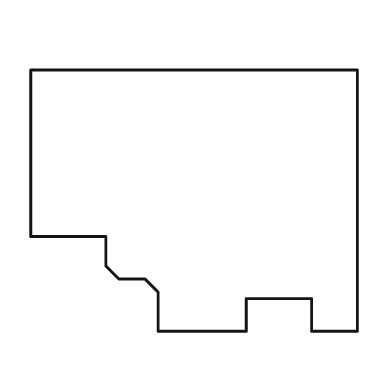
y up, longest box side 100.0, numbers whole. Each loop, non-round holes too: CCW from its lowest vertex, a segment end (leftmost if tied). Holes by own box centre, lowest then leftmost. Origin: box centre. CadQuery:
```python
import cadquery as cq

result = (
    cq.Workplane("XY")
    .moveTo(-11.0, -40.0)
    .lineTo(16.0, -40.0)
    .lineTo(16.0, -30.0)
    .lineTo(36.0, -30.0)
    .lineTo(36.0, -40.0)
    .lineTo(50.0, -40.0)
    .lineTo(50.0, 40.0)
    .lineTo(-50.0, 40.0)
    .lineTo(-50.0, -11.0)
    .lineTo(-27.0, -11.0)
    .lineTo(-27.0, -20.0)
    .lineTo(-23.0, -24.0)
    .lineTo(-15.0, -24.0)
    .lineTo(-11.0, -28.0)
    .close()
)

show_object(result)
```